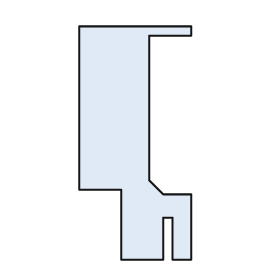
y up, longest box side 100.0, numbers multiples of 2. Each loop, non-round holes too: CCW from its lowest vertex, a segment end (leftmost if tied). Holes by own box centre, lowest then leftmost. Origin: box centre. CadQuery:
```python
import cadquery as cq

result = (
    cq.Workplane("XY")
    .moveTo(-6.0, -50.0)
    .lineTo(12.0, -50.0)
    .lineTo(12.0, -32.0)
    .lineTo(16.0, -32.0)
    .lineTo(16.0, -50.0)
    .lineTo(24.0, -50.0)
    .lineTo(24.0, -22.0)
    .lineTo(12.0, -22.0)
    .lineTo(6.0, -16.0)
    .lineTo(6.0, 46.0)
    .lineTo(24.0, 46.0)
    .lineTo(24.0, 50.0)
    .lineTo(-24.0, 50.0)
    .lineTo(-24.0, -20.0)
    .lineTo(-6.0, -20.0)
    .close()
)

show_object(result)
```